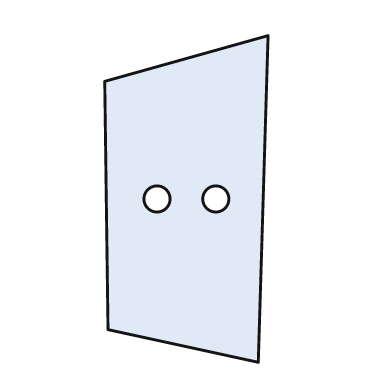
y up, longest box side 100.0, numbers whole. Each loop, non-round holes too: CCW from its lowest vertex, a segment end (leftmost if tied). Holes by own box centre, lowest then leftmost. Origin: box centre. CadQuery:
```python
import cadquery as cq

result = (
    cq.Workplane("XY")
    .moveTo(22.0, -50.0)
    .lineTo(25.0, 50.0)
    .lineTo(-25.0, 36.0)
    .lineTo(-24.0, -40.0)
    .close()
    .moveTo(-9.0, 0.0)
    .circle(4.0)
    .moveTo(9.0, 0.0)
    .circle(4.0)
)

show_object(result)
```